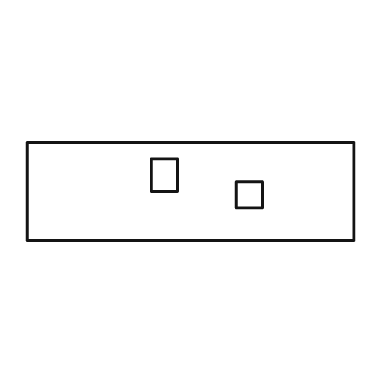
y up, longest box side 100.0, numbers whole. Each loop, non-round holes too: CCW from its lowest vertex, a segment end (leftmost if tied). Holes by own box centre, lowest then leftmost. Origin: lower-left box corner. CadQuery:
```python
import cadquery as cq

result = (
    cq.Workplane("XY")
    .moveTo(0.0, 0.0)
    .lineTo(100.0, 0.0)
    .lineTo(100.0, 30.0)
    .lineTo(0.0, 30.0)
    .close()
    .moveTo(64.0, 10.0)
    .lineTo(72.0, 10.0)
    .lineTo(72.0, 18.0)
    .lineTo(64.0, 18.0)
    .close()
    .moveTo(38.0, 15.0)
    .lineTo(46.0, 15.0)
    .lineTo(46.0, 25.0)
    .lineTo(38.0, 25.0)
    .close()
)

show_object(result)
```